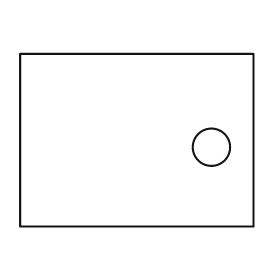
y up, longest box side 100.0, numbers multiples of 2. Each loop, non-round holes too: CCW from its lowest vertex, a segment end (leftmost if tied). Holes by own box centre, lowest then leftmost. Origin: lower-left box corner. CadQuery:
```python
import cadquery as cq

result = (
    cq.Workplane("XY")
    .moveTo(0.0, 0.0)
    .lineTo(100.0, 0.0)
    .lineTo(100.0, 74.0)
    .lineTo(0.0, 74.0)
    .close()
    .moveTo(82.0, 34.0)
    .circle(8.0)
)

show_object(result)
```